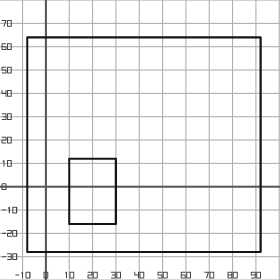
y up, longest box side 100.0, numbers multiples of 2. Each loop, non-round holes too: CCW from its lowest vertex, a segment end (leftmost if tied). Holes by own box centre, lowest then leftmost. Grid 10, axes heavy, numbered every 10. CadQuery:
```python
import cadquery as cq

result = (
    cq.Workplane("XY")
    .moveTo(-8.0, -28.0)
    .lineTo(92.0, -28.0)
    .lineTo(92.0, 64.0)
    .lineTo(-8.0, 64.0)
    .close()
    .moveTo(10.0, -16.0)
    .lineTo(30.0, -16.0)
    .lineTo(30.0, 12.0)
    .lineTo(10.0, 12.0)
    .close()
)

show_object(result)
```